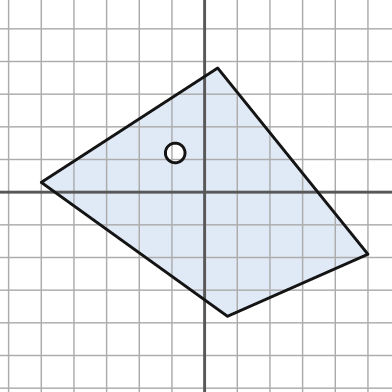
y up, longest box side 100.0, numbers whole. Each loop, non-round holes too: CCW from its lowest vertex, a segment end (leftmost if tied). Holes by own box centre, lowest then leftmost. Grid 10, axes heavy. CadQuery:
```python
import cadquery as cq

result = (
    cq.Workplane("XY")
    .moveTo(7.0, -38.0)
    .lineTo(50.0, -19.0)
    .lineTo(4.0, 38.0)
    .lineTo(-50.0, 3.0)
    .close()
    .moveTo(-9.0, 12.0)
    .circle(3.0)
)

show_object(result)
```